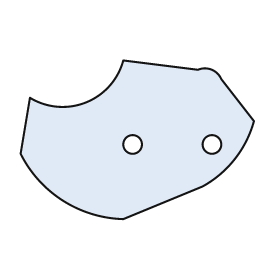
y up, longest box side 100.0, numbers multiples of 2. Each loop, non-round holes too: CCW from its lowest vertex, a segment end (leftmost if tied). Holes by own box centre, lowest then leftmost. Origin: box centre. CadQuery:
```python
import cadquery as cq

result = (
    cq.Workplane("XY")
    .moveTo(-6.0, -34.0)
    .lineTo(28.0, -20.0)
    .threePointArc((42.0, -8.0), (50.0, 8.0))
    .lineTo(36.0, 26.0)
    .threePointArc((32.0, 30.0), (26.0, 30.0))
    .lineTo(-6.0, 34.0)
    .threePointArc((-22.0, 16.0), (-46.0, 18.0))
    .lineTo(-50.0, -6.0)
    .threePointArc((-32.0, -26.0), (-6.0, -34.0))
    .close()
    .moveTo(-2.0, -2.0)
    .circle(4.0)
    .moveTo(32.0, -2.0)
    .circle(4.0)
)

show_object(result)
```